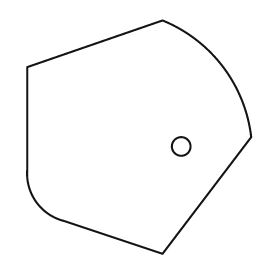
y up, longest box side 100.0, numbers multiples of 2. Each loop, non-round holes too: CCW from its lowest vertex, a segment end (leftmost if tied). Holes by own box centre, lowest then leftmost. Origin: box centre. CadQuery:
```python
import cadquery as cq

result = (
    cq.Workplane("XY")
    .moveTo(10.0, -50.0)
    .lineTo(48.0, 0.0)
    .threePointArc((36.0, 30.0), (10.0, 50.0))
    .lineTo(-48.0, 30.0)
    .lineTo(-48.0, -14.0)
    .threePointArc((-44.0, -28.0), (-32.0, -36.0))
    .close()
    .moveTo(18.0, -4.0)
    .circle(4.0)
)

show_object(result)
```